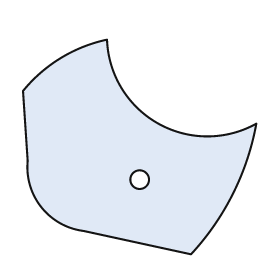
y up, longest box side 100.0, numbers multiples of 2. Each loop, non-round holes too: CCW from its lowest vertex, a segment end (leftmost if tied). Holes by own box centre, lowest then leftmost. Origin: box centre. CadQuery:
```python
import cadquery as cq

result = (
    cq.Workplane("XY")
    .moveTo(22.0, -46.0)
    .threePointArc((40.0, -20.0), (50.0, 10.0))
    .threePointArc((8.0, 10.0), (-14.0, 46.0))
    .threePointArc((-34.0, 38.0), (-50.0, 24.0))
    .lineTo(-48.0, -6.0)
    .threePointArc((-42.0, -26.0), (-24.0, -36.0))
    .close()
    .moveTo(0.0, -14.0)
    .circle(4.0)
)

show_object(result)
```